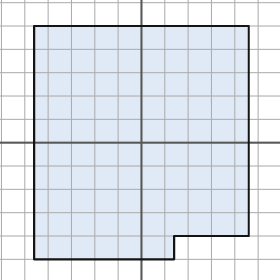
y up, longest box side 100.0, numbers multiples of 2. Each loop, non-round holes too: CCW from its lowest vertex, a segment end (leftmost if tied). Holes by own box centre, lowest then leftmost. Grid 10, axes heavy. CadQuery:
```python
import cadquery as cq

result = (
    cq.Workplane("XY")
    .moveTo(-46.0, -50.0)
    .lineTo(14.0, -50.0)
    .lineTo(14.0, -40.0)
    .lineTo(46.0, -40.0)
    .lineTo(46.0, 50.0)
    .lineTo(-46.0, 50.0)
    .close()
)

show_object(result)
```